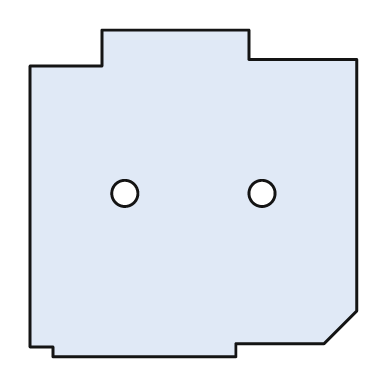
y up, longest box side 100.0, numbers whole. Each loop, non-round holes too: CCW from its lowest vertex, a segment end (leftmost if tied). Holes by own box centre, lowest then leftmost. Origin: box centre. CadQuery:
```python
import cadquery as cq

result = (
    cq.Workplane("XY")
    .moveTo(-43.0, -50.0)
    .lineTo(13.0, -50.0)
    .lineTo(13.0, -46.0)
    .lineTo(40.0, -46.0)
    .lineTo(50.0, -36.0)
    .lineTo(50.0, 41.0)
    .lineTo(17.0, 41.0)
    .lineTo(17.0, 50.0)
    .lineTo(-28.0, 50.0)
    .lineTo(-28.0, 39.0)
    .lineTo(-50.0, 39.0)
    .lineTo(-50.0, -47.0)
    .lineTo(-43.0, -47.0)
    .close()
    .moveTo(-21.0, 0.0)
    .circle(4.0)
    .moveTo(21.0, 0.0)
    .circle(4.0)
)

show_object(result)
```